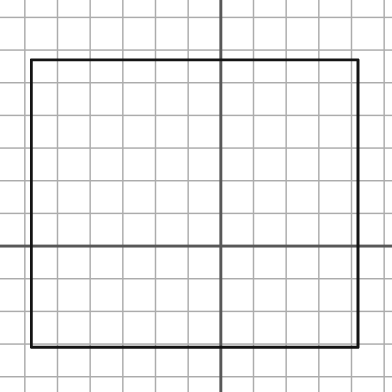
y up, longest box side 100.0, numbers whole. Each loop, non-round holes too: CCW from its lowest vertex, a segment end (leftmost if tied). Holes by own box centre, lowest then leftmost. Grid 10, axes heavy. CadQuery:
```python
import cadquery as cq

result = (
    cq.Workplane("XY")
    .moveTo(-58.0, -31.0)
    .lineTo(42.0, -31.0)
    .lineTo(42.0, 57.0)
    .lineTo(-58.0, 57.0)
    .close()
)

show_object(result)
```